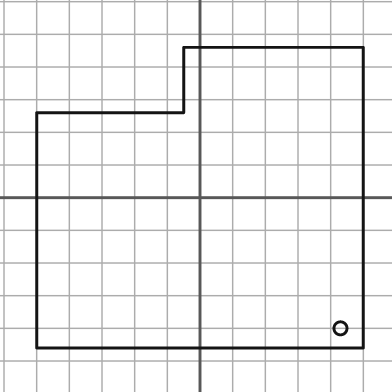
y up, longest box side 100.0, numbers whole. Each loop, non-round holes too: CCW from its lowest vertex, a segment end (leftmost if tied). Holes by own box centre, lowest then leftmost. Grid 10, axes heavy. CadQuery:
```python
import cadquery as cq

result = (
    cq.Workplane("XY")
    .moveTo(-50.0, -46.0)
    .lineTo(50.0, -46.0)
    .lineTo(50.0, 46.0)
    .lineTo(-5.0, 46.0)
    .lineTo(-5.0, 26.0)
    .lineTo(-50.0, 26.0)
    .close()
    .moveTo(43.0, -40.0)
    .circle(2.0)
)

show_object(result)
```